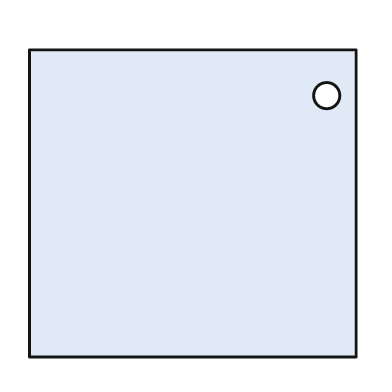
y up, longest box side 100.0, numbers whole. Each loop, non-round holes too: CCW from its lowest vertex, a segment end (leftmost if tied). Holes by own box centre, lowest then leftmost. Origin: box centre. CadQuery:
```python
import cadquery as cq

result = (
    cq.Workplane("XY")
    .moveTo(-50.0, -47.0)
    .lineTo(50.0, -47.0)
    .lineTo(50.0, 47.0)
    .lineTo(-50.0, 47.0)
    .close()
    .moveTo(41.0, 33.0)
    .circle(4.0)
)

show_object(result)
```